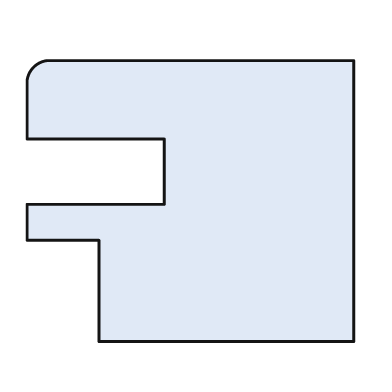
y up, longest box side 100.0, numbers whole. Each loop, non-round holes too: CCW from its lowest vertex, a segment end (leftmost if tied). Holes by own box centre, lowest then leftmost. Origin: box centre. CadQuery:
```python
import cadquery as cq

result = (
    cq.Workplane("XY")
    .moveTo(-28.0, -43.0)
    .lineTo(50.0, -43.0)
    .lineTo(50.0, 43.0)
    .lineTo(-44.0, 43.0)
    .threePointArc((-48.0, 41.0), (-50.0, 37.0))
    .lineTo(-50.0, 19.0)
    .lineTo(-8.0, 19.0)
    .lineTo(-8.0, -1.0)
    .lineTo(-50.0, -1.0)
    .lineTo(-50.0, -12.0)
    .lineTo(-28.0, -12.0)
    .close()
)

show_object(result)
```